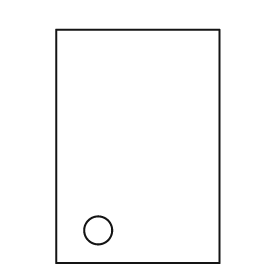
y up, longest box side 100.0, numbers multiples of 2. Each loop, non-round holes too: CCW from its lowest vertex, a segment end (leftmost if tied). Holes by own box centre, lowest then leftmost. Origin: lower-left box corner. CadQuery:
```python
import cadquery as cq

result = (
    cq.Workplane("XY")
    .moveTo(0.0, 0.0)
    .lineTo(70.0, 0.0)
    .lineTo(70.0, 100.0)
    .lineTo(0.0, 100.0)
    .close()
    .moveTo(18.0, 14.0)
    .circle(6.0)
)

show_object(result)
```